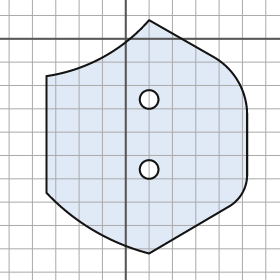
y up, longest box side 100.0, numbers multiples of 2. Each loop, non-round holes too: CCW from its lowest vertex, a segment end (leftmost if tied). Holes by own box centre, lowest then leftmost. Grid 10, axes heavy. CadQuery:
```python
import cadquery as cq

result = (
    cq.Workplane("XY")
    .moveTo(10.0, -92.0)
    .lineTo(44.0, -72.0)
    .threePointArc((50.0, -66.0), (52.0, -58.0))
    .lineTo(52.0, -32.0)
    .threePointArc((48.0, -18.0), (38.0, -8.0))
    .lineTo(10.0, 8.0)
    .threePointArc((-10.0, -8.0), (-34.0, -16.0))
    .lineTo(-34.0, -66.0)
    .threePointArc((-14.0, -82.0), (10.0, -92.0))
    .close()
    .moveTo(10.0, -56.0)
    .circle(4.0)
    .moveTo(10.0, -26.0)
    .circle(4.0)
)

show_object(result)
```